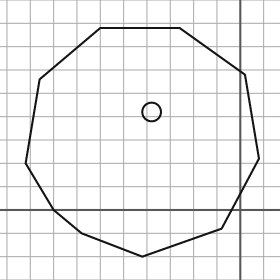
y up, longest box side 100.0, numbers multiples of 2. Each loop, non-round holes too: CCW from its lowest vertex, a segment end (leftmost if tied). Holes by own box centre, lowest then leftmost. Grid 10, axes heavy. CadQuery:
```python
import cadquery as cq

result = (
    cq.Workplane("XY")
    .moveTo(-42.0, -20.0)
    .lineTo(-8.0, -8.0)
    .lineTo(8.0, 22.0)
    .lineTo(2.0, 58.0)
    .lineTo(-26.0, 78.0)
    .lineTo(-60.0, 78.0)
    .lineTo(-86.0, 56.0)
    .lineTo(-92.0, 20.0)
    .lineTo(-80.0, 0.0)
    .lineTo(-68.0, -10.0)
    .close()
    .moveTo(-38.0, 42.0)
    .circle(4.0)
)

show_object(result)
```